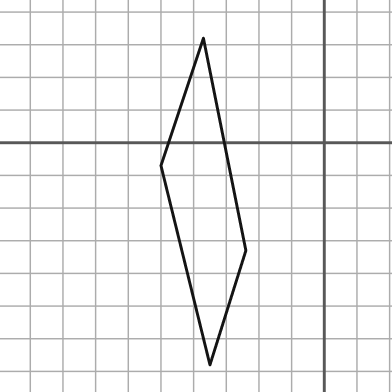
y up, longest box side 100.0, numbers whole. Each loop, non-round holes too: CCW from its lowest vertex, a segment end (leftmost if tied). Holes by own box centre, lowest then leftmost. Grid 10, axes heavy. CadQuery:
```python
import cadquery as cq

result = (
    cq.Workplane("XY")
    .moveTo(-35.0, -68.0)
    .lineTo(-24.0, -33.0)
    .lineTo(-37.0, 32.0)
    .lineTo(-50.0, -7.0)
    .close()
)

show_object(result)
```